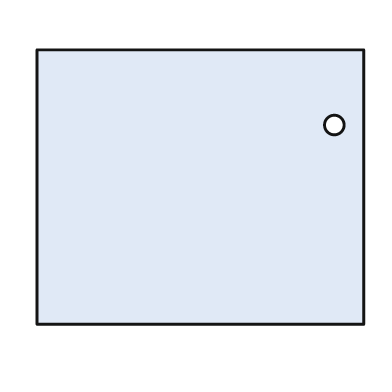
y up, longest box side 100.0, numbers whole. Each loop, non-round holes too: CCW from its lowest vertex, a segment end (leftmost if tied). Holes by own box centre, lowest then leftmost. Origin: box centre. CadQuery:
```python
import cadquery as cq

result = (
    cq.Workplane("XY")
    .moveTo(-50.0, -42.0)
    .lineTo(50.0, -42.0)
    .lineTo(50.0, 42.0)
    .lineTo(-50.0, 42.0)
    .close()
    .moveTo(41.0, 19.0)
    .circle(3.0)
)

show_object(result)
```